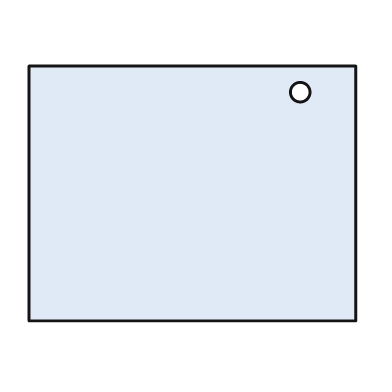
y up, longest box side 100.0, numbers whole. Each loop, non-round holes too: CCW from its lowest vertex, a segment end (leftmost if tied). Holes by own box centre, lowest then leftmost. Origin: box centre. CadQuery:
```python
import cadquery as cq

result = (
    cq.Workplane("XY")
    .moveTo(-50.0, -39.0)
    .lineTo(50.0, -39.0)
    .lineTo(50.0, 39.0)
    .lineTo(-50.0, 39.0)
    .close()
    .moveTo(33.0, 31.0)
    .circle(3.0)
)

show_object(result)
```